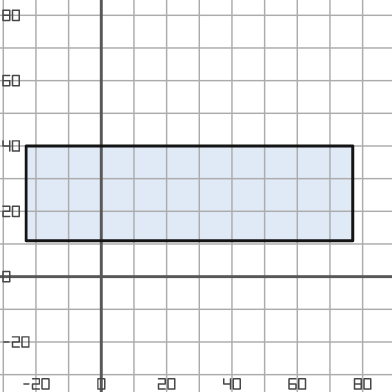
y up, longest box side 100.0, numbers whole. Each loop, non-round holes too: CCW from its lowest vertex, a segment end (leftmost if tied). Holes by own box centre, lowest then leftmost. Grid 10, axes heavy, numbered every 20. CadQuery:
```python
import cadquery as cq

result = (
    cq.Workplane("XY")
    .moveTo(-23.0, 11.0)
    .lineTo(77.0, 11.0)
    .lineTo(77.0, 40.0)
    .lineTo(-23.0, 40.0)
    .close()
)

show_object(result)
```